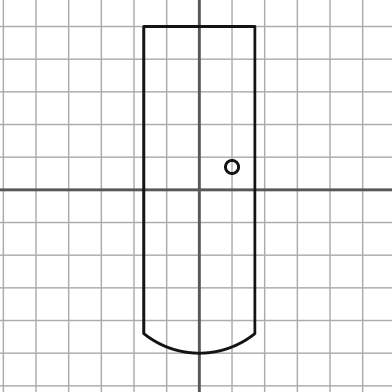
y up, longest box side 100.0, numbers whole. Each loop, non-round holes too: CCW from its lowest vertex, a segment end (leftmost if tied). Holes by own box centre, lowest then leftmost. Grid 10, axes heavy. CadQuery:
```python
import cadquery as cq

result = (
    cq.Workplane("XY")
    .moveTo(-17.0, -44.0)
    .threePointArc((0.0, -50.0), (17.0, -44.0))
    .lineTo(17.0, 50.0)
    .lineTo(-17.0, 50.0)
    .close()
    .moveTo(10.0, 7.0)
    .circle(2.0)
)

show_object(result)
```